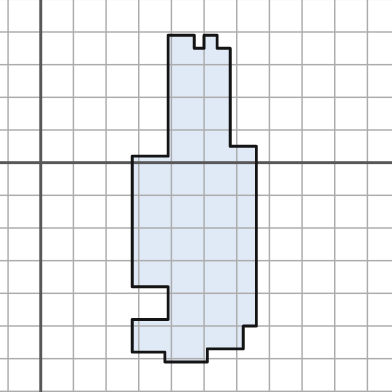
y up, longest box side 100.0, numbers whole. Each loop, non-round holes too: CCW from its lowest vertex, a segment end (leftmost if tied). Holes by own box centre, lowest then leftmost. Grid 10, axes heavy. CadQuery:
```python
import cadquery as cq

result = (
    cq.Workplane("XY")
    .moveTo(38.0, -61.0)
    .lineTo(51.0, -61.0)
    .lineTo(51.0, -57.0)
    .lineTo(62.0, -57.0)
    .lineTo(62.0, -50.0)
    .lineTo(66.0, -50.0)
    .lineTo(66.0, 5.0)
    .lineTo(58.0, 5.0)
    .lineTo(58.0, 35.0)
    .lineTo(54.0, 35.0)
    .lineTo(54.0, 39.0)
    .lineTo(50.0, 39.0)
    .lineTo(50.0, 35.0)
    .lineTo(47.0, 35.0)
    .lineTo(47.0, 39.0)
    .lineTo(39.0, 39.0)
    .lineTo(39.0, 2.0)
    .lineTo(28.0, 2.0)
    .lineTo(28.0, -38.0)
    .lineTo(39.0, -38.0)
    .lineTo(39.0, -48.0)
    .lineTo(28.0, -48.0)
    .lineTo(28.0, -58.0)
    .lineTo(38.0, -58.0)
    .close()
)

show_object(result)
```